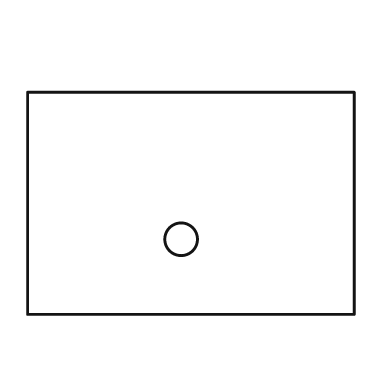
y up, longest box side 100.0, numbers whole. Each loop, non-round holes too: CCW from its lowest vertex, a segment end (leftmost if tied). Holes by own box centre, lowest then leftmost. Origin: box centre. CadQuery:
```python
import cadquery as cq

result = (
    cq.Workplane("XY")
    .moveTo(-50.0, -34.0)
    .lineTo(50.0, -34.0)
    .lineTo(50.0, 34.0)
    .lineTo(-50.0, 34.0)
    .close()
    .moveTo(-3.0, -11.0)
    .circle(5.0)
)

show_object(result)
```